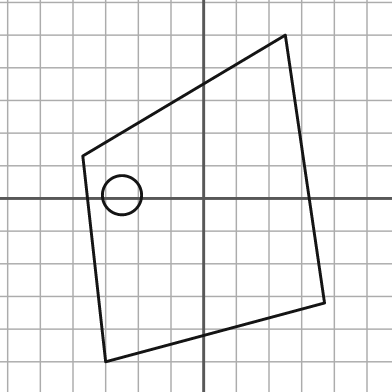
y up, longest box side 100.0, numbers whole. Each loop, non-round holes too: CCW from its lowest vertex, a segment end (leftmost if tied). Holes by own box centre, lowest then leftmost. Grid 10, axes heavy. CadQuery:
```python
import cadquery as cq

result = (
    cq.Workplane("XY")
    .moveTo(-30.0, -50.0)
    .lineTo(37.0, -32.0)
    .lineTo(25.0, 50.0)
    .lineTo(-37.0, 13.0)
    .close()
    .moveTo(-25.0, 1.0)
    .circle(6.0)
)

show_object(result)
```